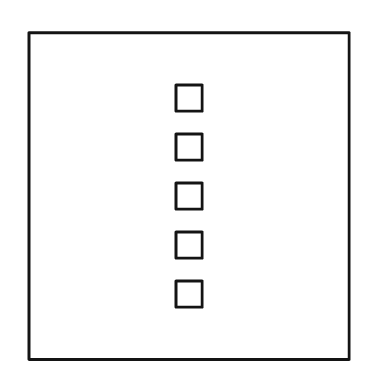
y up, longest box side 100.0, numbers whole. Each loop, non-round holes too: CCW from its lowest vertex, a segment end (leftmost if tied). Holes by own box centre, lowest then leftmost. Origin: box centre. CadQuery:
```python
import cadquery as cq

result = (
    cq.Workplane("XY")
    .moveTo(-49.0, -50.0)
    .lineTo(49.0, -50.0)
    .lineTo(49.0, 50.0)
    .lineTo(-49.0, 50.0)
    .close()
    .moveTo(-4.0, -34.0)
    .lineTo(4.0, -34.0)
    .lineTo(4.0, -26.0)
    .lineTo(-4.0, -26.0)
    .close()
    .moveTo(-4.0, -19.0)
    .lineTo(4.0, -19.0)
    .lineTo(4.0, -11.0)
    .lineTo(-4.0, -11.0)
    .close()
    .moveTo(-4.0, -4.0)
    .lineTo(4.0, -4.0)
    .lineTo(4.0, 4.0)
    .lineTo(-4.0, 4.0)
    .close()
    .moveTo(-4.0, 11.0)
    .lineTo(4.0, 11.0)
    .lineTo(4.0, 19.0)
    .lineTo(-4.0, 19.0)
    .close()
    .moveTo(-4.0, 26.0)
    .lineTo(4.0, 26.0)
    .lineTo(4.0, 34.0)
    .lineTo(-4.0, 34.0)
    .close()
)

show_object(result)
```